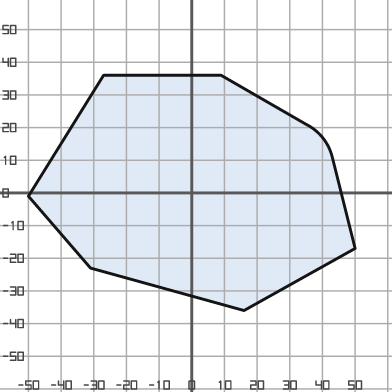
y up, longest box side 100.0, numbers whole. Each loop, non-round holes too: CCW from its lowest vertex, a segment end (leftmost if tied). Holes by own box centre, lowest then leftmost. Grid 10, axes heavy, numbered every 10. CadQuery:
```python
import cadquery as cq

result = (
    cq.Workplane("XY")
    .moveTo(16.0, -36.0)
    .lineTo(50.0, -17.0)
    .lineTo(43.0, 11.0)
    .threePointArc((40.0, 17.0), (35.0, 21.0))
    .lineTo(9.0, 36.0)
    .lineTo(-27.0, 36.0)
    .lineTo(-50.0, -1.0)
    .lineTo(-31.0, -23.0)
    .close()
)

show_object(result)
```